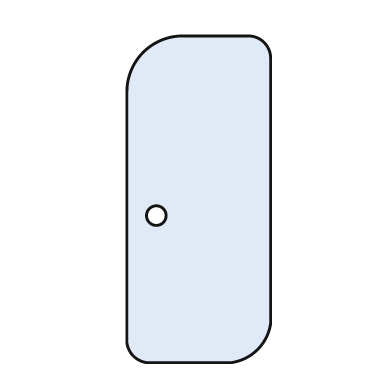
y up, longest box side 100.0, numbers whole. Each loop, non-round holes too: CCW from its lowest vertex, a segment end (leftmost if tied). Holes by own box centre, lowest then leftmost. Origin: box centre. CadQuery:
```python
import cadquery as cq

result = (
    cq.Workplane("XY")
    .moveTo(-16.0, -50.0)
    .lineTo(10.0, -50.0)
    .threePointArc((18.0, -46.0), (22.0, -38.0))
    .lineTo(22.0, 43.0)
    .threePointArc((20.0, 48.0), (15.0, 50.0))
    .lineTo(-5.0, 50.0)
    .threePointArc((-17.0, 45.0), (-22.0, 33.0))
    .lineTo(-22.0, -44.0)
    .threePointArc((-20.0, -48.0), (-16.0, -50.0))
    .close()
    .moveTo(-13.0, -5.0)
    .circle(3.0)
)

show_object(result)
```